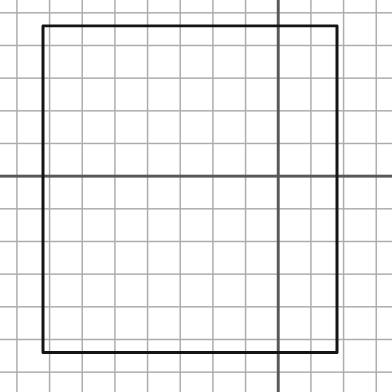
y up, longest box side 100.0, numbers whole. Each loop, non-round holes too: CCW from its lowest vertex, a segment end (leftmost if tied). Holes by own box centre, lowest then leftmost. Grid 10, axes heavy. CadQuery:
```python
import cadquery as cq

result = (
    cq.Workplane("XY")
    .moveTo(-72.0, -54.0)
    .lineTo(18.0, -54.0)
    .lineTo(18.0, 46.0)
    .lineTo(-72.0, 46.0)
    .close()
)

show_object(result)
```